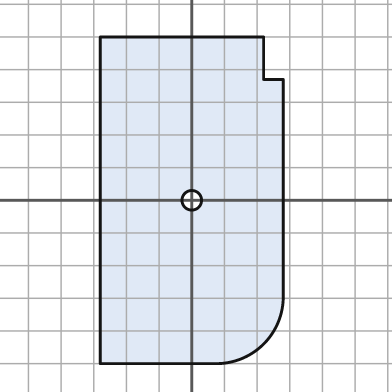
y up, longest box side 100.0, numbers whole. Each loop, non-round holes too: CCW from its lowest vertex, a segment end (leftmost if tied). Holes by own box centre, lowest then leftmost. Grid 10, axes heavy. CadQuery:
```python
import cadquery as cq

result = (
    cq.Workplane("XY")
    .moveTo(-28.0, -50.0)
    .lineTo(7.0, -50.0)
    .threePointArc((22.0, -44.0), (28.0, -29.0))
    .lineTo(28.0, 37.0)
    .lineTo(22.0, 37.0)
    .lineTo(22.0, 50.0)
    .lineTo(-28.0, 50.0)
    .close()
    .moveTo(0.0, 0.0)
    .circle(3.0)
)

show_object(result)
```